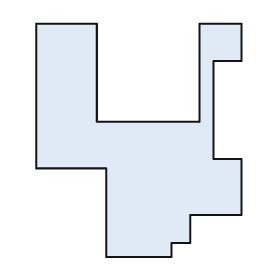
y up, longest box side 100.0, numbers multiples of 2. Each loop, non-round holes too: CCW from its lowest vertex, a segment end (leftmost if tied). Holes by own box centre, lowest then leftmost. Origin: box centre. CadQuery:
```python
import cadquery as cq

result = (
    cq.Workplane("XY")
    .moveTo(-14.0, -50.0)
    .lineTo(14.0, -50.0)
    .lineTo(14.0, -44.0)
    .lineTo(22.0, -44.0)
    .lineTo(22.0, -32.0)
    .lineTo(44.0, -32.0)
    .lineTo(44.0, -8.0)
    .lineTo(32.0, -8.0)
    .lineTo(32.0, 34.0)
    .lineTo(44.0, 34.0)
    .lineTo(44.0, 50.0)
    .lineTo(26.0, 50.0)
    .lineTo(26.0, 8.0)
    .lineTo(-18.0, 8.0)
    .lineTo(-18.0, 50.0)
    .lineTo(-44.0, 50.0)
    .lineTo(-44.0, -12.0)
    .lineTo(-14.0, -12.0)
    .close()
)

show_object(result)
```